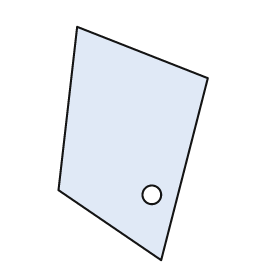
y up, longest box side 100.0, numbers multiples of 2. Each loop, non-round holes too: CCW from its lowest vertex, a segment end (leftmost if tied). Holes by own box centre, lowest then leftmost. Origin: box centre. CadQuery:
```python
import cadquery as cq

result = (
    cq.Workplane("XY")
    .moveTo(12.0, -50.0)
    .lineTo(32.0, 28.0)
    .lineTo(-24.0, 50.0)
    .lineTo(-32.0, -20.0)
    .close()
    .moveTo(8.0, -22.0)
    .circle(4.0)
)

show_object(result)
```